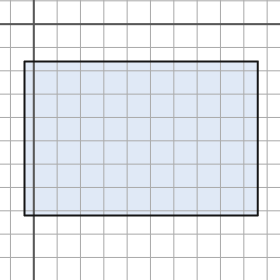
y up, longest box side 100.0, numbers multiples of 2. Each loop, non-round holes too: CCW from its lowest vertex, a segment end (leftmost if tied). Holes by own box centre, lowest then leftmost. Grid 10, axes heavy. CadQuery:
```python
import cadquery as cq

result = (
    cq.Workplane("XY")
    .moveTo(-4.0, -82.0)
    .lineTo(96.0, -82.0)
    .lineTo(96.0, -16.0)
    .lineTo(-4.0, -16.0)
    .close()
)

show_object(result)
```